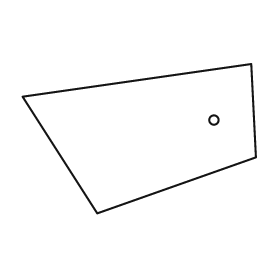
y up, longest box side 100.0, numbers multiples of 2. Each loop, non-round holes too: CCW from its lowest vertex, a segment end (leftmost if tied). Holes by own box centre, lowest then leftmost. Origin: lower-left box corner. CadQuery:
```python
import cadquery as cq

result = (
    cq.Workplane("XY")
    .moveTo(32.0, 0.0)
    .lineTo(100.0, 24.0)
    .lineTo(98.0, 64.0)
    .lineTo(0.0, 50.0)
    .close()
    .moveTo(82.0, 40.0)
    .circle(2.0)
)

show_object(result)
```